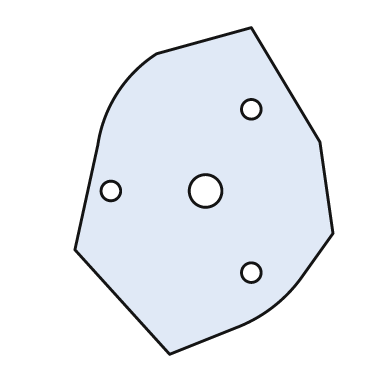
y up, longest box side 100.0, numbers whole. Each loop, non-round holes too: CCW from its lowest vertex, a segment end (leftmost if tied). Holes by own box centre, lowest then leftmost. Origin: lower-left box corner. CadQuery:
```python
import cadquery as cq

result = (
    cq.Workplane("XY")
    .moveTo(29.0, 0.0)
    .lineTo(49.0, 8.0)
    .threePointArc((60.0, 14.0), (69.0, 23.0))
    .lineTo(79.0, 37.0)
    .lineTo(75.0, 65.0)
    .lineTo(54.0, 100.0)
    .lineTo(25.0, 92.0)
    .threePointArc((13.0, 80.0), (7.0, 64.0))
    .lineTo(0.0, 32.0)
    .close()
    .moveTo(54.0, 25.0)
    .circle(3.0)
    .moveTo(11.0, 50.0)
    .circle(3.0)
    .moveTo(40.0, 50.0)
    .circle(5.0)
    .moveTo(54.0, 75.0)
    .circle(3.0)
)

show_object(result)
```